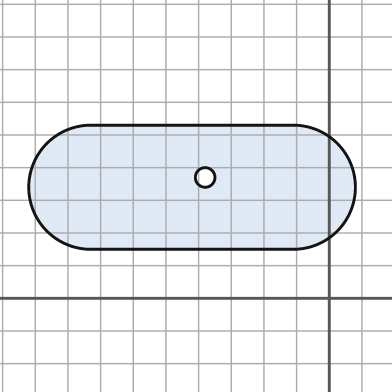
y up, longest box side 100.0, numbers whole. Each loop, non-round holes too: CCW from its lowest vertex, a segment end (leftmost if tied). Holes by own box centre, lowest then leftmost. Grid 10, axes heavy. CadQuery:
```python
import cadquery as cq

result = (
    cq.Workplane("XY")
    .moveTo(-73.0, 15.0)
    .lineTo(-11.0, 15.0)
    .threePointArc((8.0, 34.0), (-11.0, 53.0))
    .lineTo(-73.0, 53.0)
    .threePointArc((-92.0, 34.0), (-73.0, 15.0))
    .close()
    .moveTo(-38.0, 37.0)
    .circle(3.0)
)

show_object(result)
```